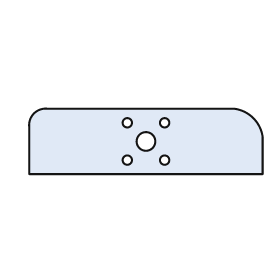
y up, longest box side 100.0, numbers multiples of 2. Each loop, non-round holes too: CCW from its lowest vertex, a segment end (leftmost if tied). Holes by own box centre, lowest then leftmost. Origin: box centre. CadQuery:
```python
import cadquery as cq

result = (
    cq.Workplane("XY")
    .moveTo(-50.0, -14.0)
    .lineTo(50.0, -14.0)
    .lineTo(50.0, 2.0)
    .threePointArc((46.0, 10.0), (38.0, 14.0))
    .lineTo(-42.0, 14.0)
    .threePointArc((-48.0, 12.0), (-50.0, 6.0))
    .close()
    .moveTo(-8.0, -8.0)
    .circle(2.0)
    .moveTo(8.0, -8.0)
    .circle(2.0)
    .moveTo(0.0, 0.0)
    .circle(4.0)
    .moveTo(-8.0, 8.0)
    .circle(2.0)
    .moveTo(8.0, 8.0)
    .circle(2.0)
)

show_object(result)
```